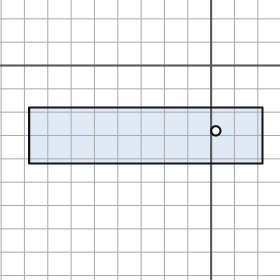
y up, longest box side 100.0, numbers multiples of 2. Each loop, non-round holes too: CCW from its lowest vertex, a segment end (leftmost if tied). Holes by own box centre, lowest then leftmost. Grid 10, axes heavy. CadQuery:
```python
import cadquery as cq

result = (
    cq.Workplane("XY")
    .moveTo(-78.0, -42.0)
    .lineTo(22.0, -42.0)
    .lineTo(22.0, -18.0)
    .lineTo(-78.0, -18.0)
    .close()
    .moveTo(2.0, -28.0)
    .circle(2.0)
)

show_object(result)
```